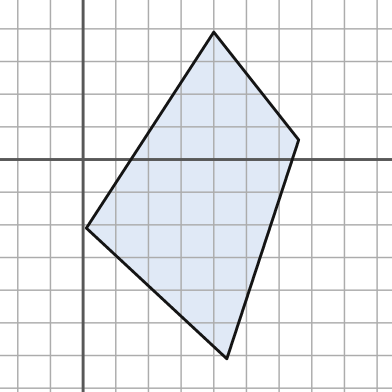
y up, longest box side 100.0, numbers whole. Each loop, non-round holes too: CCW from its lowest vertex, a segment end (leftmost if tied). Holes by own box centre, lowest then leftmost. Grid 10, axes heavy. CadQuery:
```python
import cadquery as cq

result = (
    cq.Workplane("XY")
    .moveTo(44.0, -61.0)
    .lineTo(66.0, 6.0)
    .lineTo(40.0, 39.0)
    .lineTo(1.0, -21.0)
    .close()
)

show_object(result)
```